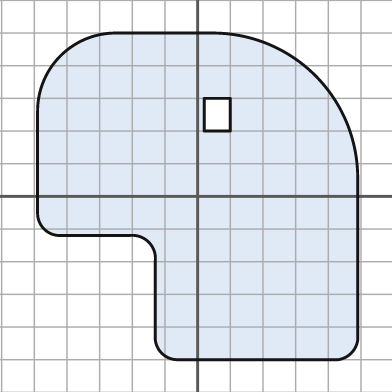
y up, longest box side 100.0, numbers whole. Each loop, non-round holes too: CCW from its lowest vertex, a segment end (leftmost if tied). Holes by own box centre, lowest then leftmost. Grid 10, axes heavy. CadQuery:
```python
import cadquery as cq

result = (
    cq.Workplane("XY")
    .moveTo(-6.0, -50.0)
    .lineTo(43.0, -50.0)
    .threePointArc((47.0, -48.0), (49.0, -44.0))
    .lineTo(49.0, 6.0)
    .threePointArc((36.0, 37.0), (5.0, 50.0))
    .lineTo(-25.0, 50.0)
    .threePointArc((-42.0, 43.0), (-49.0, 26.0))
    .lineTo(-49.0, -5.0)
    .threePointArc((-47.0, -10.0), (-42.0, -12.0))
    .lineTo(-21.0, -12.0)
    .threePointArc((-15.0, -14.0), (-13.0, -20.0))
    .lineTo(-13.0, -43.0)
    .threePointArc((-11.0, -48.0), (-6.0, -50.0))
    .close()
    .moveTo(2.0, 20.0)
    .lineTo(10.0, 20.0)
    .lineTo(10.0, 30.0)
    .lineTo(2.0, 30.0)
    .close()
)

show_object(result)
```